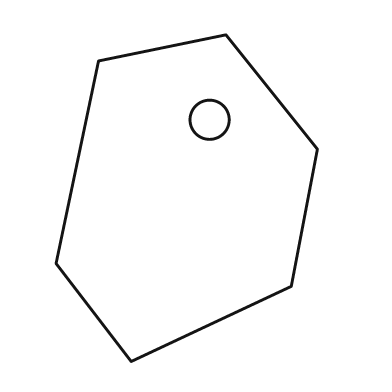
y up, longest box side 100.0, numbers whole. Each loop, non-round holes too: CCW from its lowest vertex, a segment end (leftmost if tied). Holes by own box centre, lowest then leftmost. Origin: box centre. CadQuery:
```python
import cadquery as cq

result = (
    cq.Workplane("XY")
    .moveTo(-17.0, -50.0)
    .lineTo(32.0, -27.0)
    .lineTo(40.0, 15.0)
    .lineTo(12.0, 50.0)
    .lineTo(-27.0, 42.0)
    .lineTo(-40.0, -20.0)
    .close()
    .moveTo(7.0, 24.0)
    .circle(6.0)
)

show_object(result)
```